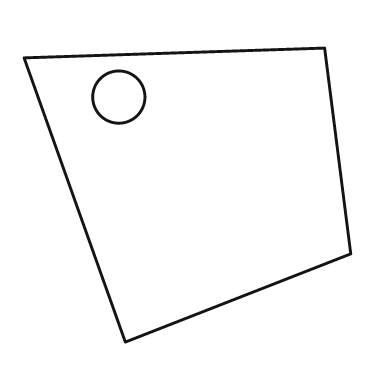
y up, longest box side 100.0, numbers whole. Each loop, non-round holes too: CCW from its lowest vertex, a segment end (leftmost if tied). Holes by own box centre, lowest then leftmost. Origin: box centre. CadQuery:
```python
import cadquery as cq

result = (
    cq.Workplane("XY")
    .moveTo(-19.0, -45.0)
    .lineTo(50.0, -18.0)
    .lineTo(42.0, 45.0)
    .lineTo(-50.0, 42.0)
    .close()
    .moveTo(-21.0, 30.0)
    .circle(8.0)
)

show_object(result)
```